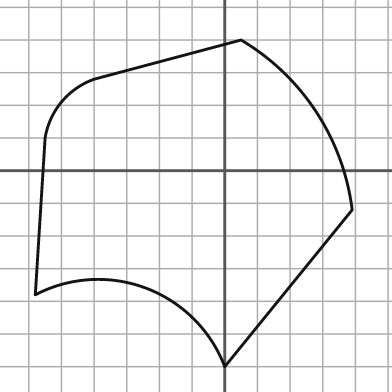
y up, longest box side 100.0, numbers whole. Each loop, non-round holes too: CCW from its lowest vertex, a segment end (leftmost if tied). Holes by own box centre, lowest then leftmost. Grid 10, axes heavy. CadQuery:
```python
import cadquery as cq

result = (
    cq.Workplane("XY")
    .moveTo(0.0, -60.0)
    .lineTo(39.0, -12.0)
    .threePointArc((28.0, 18.0), (5.0, 40.0))
    .lineTo(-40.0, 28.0)
    .threePointArc((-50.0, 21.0), (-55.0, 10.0))
    .lineTo(-58.0, -38.0)
    .threePointArc((-24.0, -36.0), (0.0, -60.0))
    .close()
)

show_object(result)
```